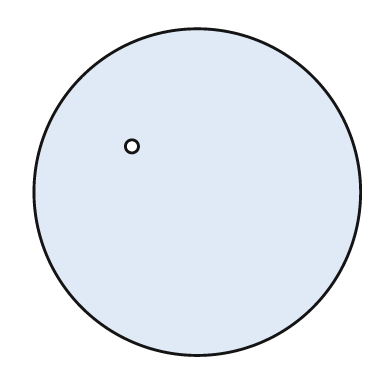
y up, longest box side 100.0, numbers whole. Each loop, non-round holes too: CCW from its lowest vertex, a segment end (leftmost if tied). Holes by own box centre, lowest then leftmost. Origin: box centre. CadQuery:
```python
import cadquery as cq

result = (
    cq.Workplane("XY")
    .moveTo(0.0, 0.0)
    .circle(50.0)
    .moveTo(-20.0, 14.0)
    .circle(2.0)
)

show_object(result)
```